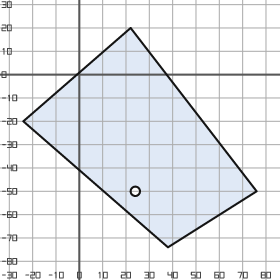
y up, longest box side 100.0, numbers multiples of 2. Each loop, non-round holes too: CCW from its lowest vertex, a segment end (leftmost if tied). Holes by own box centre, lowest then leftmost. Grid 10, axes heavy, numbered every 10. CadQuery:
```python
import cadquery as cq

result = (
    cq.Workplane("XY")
    .moveTo(38.0, -74.0)
    .lineTo(76.0, -50.0)
    .lineTo(22.0, 20.0)
    .lineTo(-24.0, -20.0)
    .close()
    .moveTo(24.0, -50.0)
    .circle(2.0)
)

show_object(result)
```